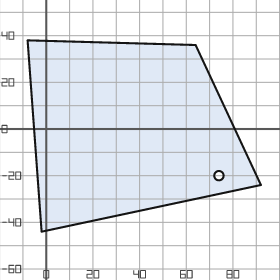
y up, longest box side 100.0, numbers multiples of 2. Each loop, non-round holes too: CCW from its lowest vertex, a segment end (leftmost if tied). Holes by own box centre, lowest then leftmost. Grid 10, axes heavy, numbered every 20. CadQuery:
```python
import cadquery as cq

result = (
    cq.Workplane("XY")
    .moveTo(-2.0, -44.0)
    .lineTo(92.0, -24.0)
    .lineTo(64.0, 36.0)
    .lineTo(-8.0, 38.0)
    .close()
    .moveTo(74.0, -20.0)
    .circle(2.0)
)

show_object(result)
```